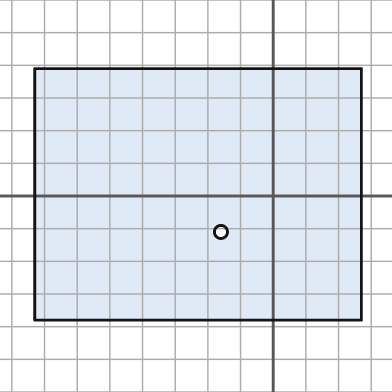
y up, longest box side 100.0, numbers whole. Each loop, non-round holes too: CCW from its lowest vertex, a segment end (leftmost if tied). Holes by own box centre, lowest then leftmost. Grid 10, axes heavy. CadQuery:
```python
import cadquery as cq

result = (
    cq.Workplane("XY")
    .moveTo(-73.0, -38.0)
    .lineTo(27.0, -38.0)
    .lineTo(27.0, 39.0)
    .lineTo(-73.0, 39.0)
    .close()
    .moveTo(-16.0, -11.0)
    .circle(2.0)
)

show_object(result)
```